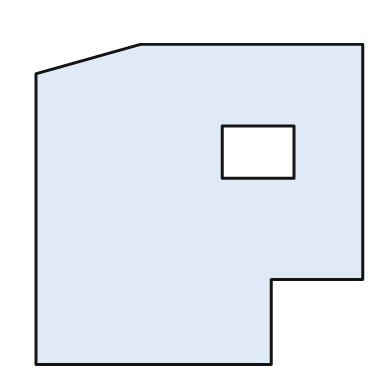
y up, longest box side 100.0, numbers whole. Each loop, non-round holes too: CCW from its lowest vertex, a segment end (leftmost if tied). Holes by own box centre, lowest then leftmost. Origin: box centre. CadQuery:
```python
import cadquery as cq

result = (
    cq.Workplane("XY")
    .moveTo(-50.0, -49.0)
    .lineTo(22.0, -49.0)
    .lineTo(22.0, -23.0)
    .lineTo(50.0, -23.0)
    .lineTo(50.0, 49.0)
    .lineTo(-18.0, 49.0)
    .lineTo(-50.0, 40.0)
    .close()
    .moveTo(7.0, 8.0)
    .lineTo(29.0, 8.0)
    .lineTo(29.0, 24.0)
    .lineTo(7.0, 24.0)
    .close()
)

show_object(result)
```